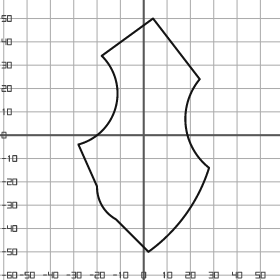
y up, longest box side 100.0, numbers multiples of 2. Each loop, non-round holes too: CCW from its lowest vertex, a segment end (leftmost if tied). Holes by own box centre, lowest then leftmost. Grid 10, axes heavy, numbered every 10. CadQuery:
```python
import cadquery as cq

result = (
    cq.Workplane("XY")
    .moveTo(2.0, -50.0)
    .threePointArc((18.0, -34.0), (28.0, -14.0))
    .threePointArc((18.0, 4.0), (24.0, 24.0))
    .lineTo(4.0, 50.0)
    .lineTo(-18.0, 34.0)
    .threePointArc((-12.0, 12.0), (-28.0, -4.0))
    .lineTo(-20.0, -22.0)
    .threePointArc((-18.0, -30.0), (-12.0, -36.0))
    .close()
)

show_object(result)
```